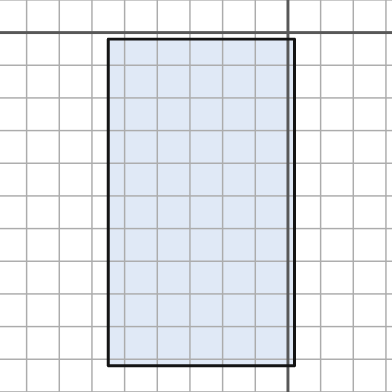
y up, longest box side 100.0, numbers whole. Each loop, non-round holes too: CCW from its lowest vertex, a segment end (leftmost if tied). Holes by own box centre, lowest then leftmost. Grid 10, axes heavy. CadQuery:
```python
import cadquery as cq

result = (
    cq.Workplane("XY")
    .moveTo(-55.0, -102.0)
    .lineTo(2.0, -102.0)
    .lineTo(2.0, -2.0)
    .lineTo(-55.0, -2.0)
    .close()
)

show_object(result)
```